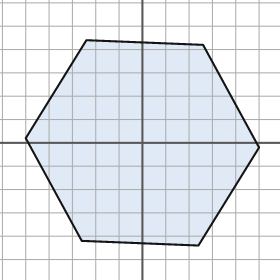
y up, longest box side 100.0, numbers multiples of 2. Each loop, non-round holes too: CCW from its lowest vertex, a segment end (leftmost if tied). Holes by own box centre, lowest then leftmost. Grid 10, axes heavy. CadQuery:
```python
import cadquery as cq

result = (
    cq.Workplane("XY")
    .moveTo(24.0, -44.0)
    .lineTo(50.0, -2.0)
    .lineTo(26.0, 42.0)
    .lineTo(-24.0, 44.0)
    .lineTo(-50.0, 2.0)
    .lineTo(-26.0, -42.0)
    .close()
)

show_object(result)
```